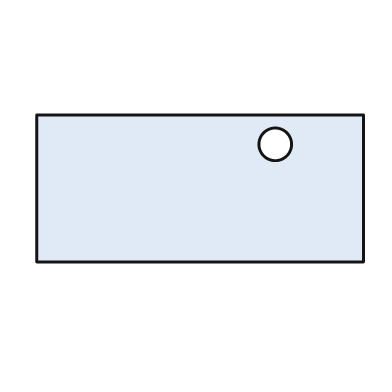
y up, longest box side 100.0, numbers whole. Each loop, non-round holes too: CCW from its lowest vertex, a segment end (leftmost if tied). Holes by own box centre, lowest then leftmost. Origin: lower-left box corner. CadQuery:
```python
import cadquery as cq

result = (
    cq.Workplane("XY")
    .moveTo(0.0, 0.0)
    .lineTo(100.0, 0.0)
    .lineTo(100.0, 45.0)
    .lineTo(0.0, 45.0)
    .close()
    .moveTo(73.0, 36.0)
    .circle(5.0)
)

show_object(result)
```